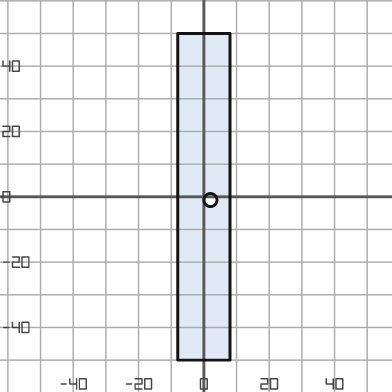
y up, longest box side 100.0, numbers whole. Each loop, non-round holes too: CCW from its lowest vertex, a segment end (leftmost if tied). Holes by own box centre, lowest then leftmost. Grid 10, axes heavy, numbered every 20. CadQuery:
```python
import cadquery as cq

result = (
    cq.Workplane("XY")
    .moveTo(-8.0, -50.0)
    .lineTo(8.0, -50.0)
    .lineTo(8.0, 50.0)
    .lineTo(-8.0, 50.0)
    .close()
    .moveTo(2.0, -1.0)
    .circle(2.0)
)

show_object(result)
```